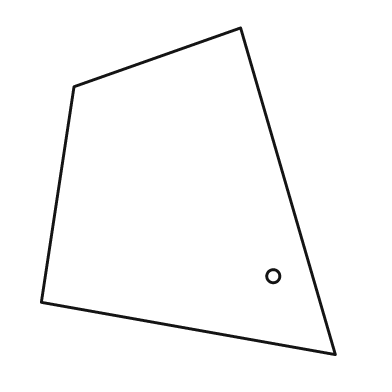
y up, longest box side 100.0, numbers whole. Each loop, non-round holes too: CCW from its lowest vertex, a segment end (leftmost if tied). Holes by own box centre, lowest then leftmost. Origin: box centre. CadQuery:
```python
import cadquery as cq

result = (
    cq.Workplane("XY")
    .moveTo(45.0, -50.0)
    .lineTo(16.0, 50.0)
    .lineTo(-35.0, 32.0)
    .lineTo(-45.0, -34.0)
    .close()
    .moveTo(26.0, -26.0)
    .circle(2.0)
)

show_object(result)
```